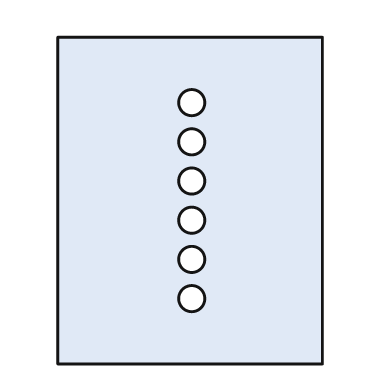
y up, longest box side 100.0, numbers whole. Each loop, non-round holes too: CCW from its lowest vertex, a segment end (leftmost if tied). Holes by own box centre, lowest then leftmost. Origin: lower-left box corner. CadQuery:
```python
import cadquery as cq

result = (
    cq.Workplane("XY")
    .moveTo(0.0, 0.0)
    .lineTo(81.0, 0.0)
    .lineTo(81.0, 100.0)
    .lineTo(0.0, 100.0)
    .close()
    .moveTo(41.0, 20.0)
    .circle(4.0)
    .moveTo(41.0, 32.0)
    .circle(4.0)
    .moveTo(41.0, 44.0)
    .circle(4.0)
    .moveTo(41.0, 56.0)
    .circle(4.0)
    .moveTo(41.0, 68.0)
    .circle(4.0)
    .moveTo(41.0, 80.0)
    .circle(4.0)
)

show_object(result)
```